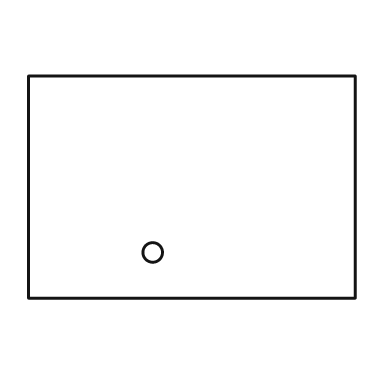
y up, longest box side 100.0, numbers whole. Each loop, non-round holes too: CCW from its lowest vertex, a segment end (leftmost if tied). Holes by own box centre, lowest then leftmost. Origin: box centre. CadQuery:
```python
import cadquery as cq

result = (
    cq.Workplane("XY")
    .moveTo(-50.0, -34.0)
    .lineTo(50.0, -34.0)
    .lineTo(50.0, 34.0)
    .lineTo(-50.0, 34.0)
    .close()
    .moveTo(-12.0, -20.0)
    .circle(3.0)
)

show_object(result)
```